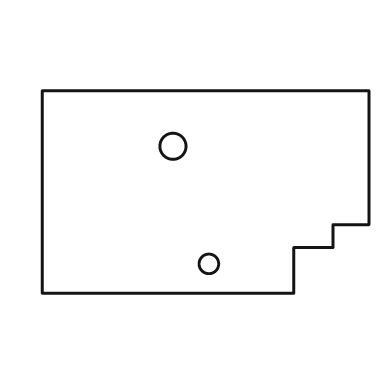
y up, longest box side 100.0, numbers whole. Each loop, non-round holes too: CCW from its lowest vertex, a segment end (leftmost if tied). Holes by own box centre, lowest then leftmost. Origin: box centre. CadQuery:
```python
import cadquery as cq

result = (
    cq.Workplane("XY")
    .moveTo(-50.0, -31.0)
    .lineTo(27.0, -31.0)
    .lineTo(27.0, -17.0)
    .lineTo(39.0, -17.0)
    .lineTo(39.0, -10.0)
    .lineTo(50.0, -10.0)
    .lineTo(50.0, 31.0)
    .lineTo(-50.0, 31.0)
    .close()
    .moveTo(1.0, -22.0)
    .circle(3.0)
    .moveTo(-10.0, 14.0)
    .circle(4.0)
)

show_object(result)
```